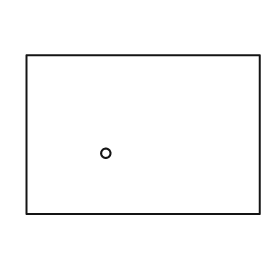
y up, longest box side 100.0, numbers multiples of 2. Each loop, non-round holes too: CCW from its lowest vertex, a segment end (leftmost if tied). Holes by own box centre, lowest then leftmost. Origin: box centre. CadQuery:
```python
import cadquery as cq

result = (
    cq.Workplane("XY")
    .moveTo(-50.0, -34.0)
    .lineTo(50.0, -34.0)
    .lineTo(50.0, 34.0)
    .lineTo(-50.0, 34.0)
    .close()
    .moveTo(-16.0, -8.0)
    .circle(2.0)
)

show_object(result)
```